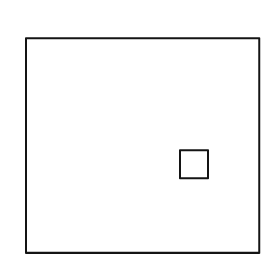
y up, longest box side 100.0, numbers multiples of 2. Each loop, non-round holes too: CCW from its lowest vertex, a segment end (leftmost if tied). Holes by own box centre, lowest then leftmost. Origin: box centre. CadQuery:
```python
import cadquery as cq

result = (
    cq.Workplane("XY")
    .moveTo(-50.0, -46.0)
    .lineTo(50.0, -46.0)
    .lineTo(50.0, 46.0)
    .lineTo(-50.0, 46.0)
    .close()
    .moveTo(16.0, -14.0)
    .lineTo(28.0, -14.0)
    .lineTo(28.0, -2.0)
    .lineTo(16.0, -2.0)
    .close()
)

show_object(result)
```